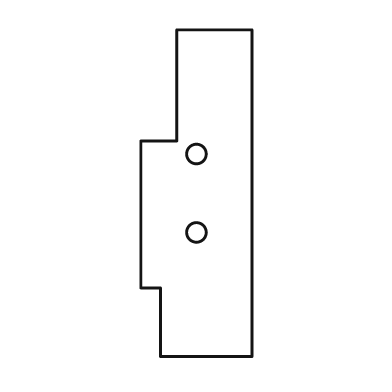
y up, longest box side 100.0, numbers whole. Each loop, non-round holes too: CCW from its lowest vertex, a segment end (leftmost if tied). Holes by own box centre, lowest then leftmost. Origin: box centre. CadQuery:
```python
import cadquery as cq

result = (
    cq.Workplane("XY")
    .moveTo(-11.0, -50.0)
    .lineTo(17.0, -50.0)
    .lineTo(17.0, 50.0)
    .lineTo(-6.0, 50.0)
    .lineTo(-6.0, 16.0)
    .lineTo(-17.0, 16.0)
    .lineTo(-17.0, -29.0)
    .lineTo(-11.0, -29.0)
    .close()
    .moveTo(0.0, -12.0)
    .circle(3.0)
    .moveTo(0.0, 12.0)
    .circle(3.0)
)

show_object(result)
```